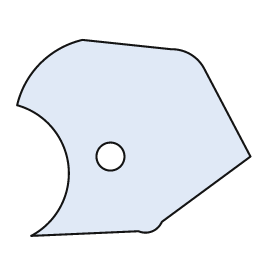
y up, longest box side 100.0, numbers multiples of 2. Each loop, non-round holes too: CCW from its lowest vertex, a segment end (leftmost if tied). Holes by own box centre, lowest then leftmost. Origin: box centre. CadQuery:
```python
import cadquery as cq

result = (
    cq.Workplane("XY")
    .moveTo(-44.0, -42.0)
    .lineTo(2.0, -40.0)
    .threePointArc((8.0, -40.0), (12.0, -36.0))
    .lineTo(50.0, -8.0)
    .lineTo(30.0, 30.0)
    .threePointArc((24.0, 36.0), (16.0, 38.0))
    .lineTo(-22.0, 42.0)
    .threePointArc((-40.0, 32.0), (-50.0, 14.0))
    .threePointArc((-28.0, -12.0), (-44.0, -42.0))
    .close()
    .moveTo(-10.0, -8.0)
    .circle(6.0)
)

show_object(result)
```